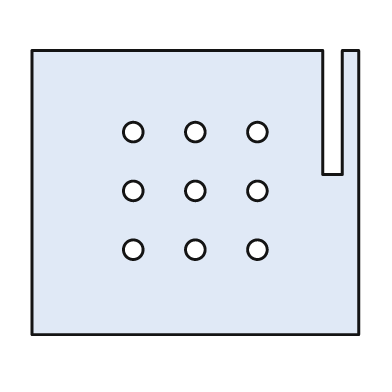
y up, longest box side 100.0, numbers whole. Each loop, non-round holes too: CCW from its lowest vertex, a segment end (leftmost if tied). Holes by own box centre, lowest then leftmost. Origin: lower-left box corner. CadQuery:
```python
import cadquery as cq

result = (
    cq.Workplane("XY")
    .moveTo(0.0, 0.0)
    .lineTo(100.0, 0.0)
    .lineTo(100.0, 87.0)
    .lineTo(95.0, 87.0)
    .lineTo(95.0, 49.0)
    .lineTo(89.0, 49.0)
    .lineTo(89.0, 87.0)
    .lineTo(0.0, 87.0)
    .close()
    .moveTo(31.0, 26.0)
    .circle(3.0)
    .moveTo(50.0, 26.0)
    .circle(3.0)
    .moveTo(69.0, 26.0)
    .circle(3.0)
    .moveTo(31.0, 44.0)
    .circle(3.0)
    .moveTo(50.0, 44.0)
    .circle(3.0)
    .moveTo(69.0, 44.0)
    .circle(3.0)
    .moveTo(31.0, 62.0)
    .circle(3.0)
    .moveTo(50.0, 62.0)
    .circle(3.0)
    .moveTo(69.0, 62.0)
    .circle(3.0)
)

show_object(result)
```